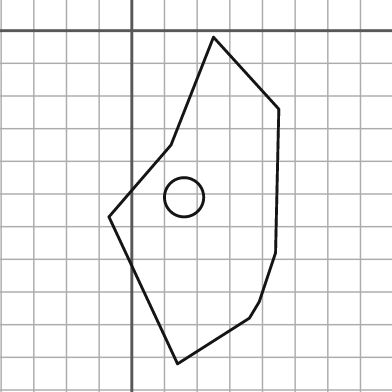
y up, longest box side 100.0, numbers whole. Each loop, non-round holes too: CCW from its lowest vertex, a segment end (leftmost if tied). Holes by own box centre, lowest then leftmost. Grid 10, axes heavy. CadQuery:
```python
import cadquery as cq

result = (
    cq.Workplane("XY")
    .moveTo(14.0, -102.0)
    .lineTo(36.0, -88.0)
    .lineTo(39.0, -83.0)
    .lineTo(44.0, -68.0)
    .lineTo(45.0, -24.0)
    .lineTo(25.0, -2.0)
    .lineTo(12.0, -35.0)
    .lineTo(-7.0, -57.0)
    .close()
    .moveTo(16.0, -51.0)
    .circle(6.0)
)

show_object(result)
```